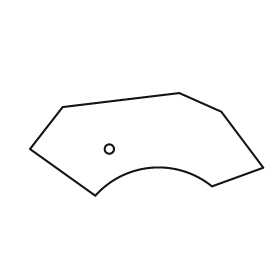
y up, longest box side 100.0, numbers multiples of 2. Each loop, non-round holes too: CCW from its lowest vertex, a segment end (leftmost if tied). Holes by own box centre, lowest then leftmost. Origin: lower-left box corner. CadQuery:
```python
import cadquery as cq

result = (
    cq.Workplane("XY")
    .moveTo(28.0, 0.0)
    .threePointArc((52.0, 12.0), (78.0, 4.0))
    .lineTo(100.0, 12.0)
    .lineTo(82.0, 36.0)
    .lineTo(64.0, 44.0)
    .lineTo(14.0, 38.0)
    .lineTo(0.0, 20.0)
    .close()
    .moveTo(34.0, 20.0)
    .circle(2.0)
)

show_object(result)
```